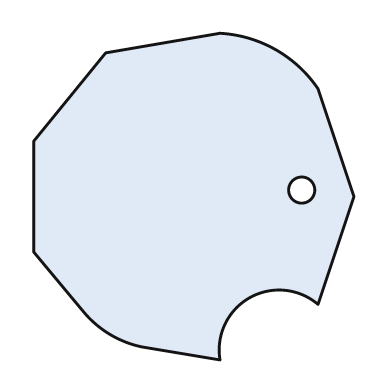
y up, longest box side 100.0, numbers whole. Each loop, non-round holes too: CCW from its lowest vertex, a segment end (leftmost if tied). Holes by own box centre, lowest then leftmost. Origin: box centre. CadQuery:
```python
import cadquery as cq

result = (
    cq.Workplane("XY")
    .moveTo(8.0, -50.0)
    .threePointArc((17.0, -31.0), (38.0, -33.0))
    .lineTo(49.0, 0.0)
    .lineTo(38.0, 33.0)
    .threePointArc((25.0, 45.0), (8.0, 50.0))
    .lineTo(-27.0, 44.0)
    .lineTo(-49.0, 17.0)
    .lineTo(-49.0, -17.0)
    .lineTo(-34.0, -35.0)
    .threePointArc((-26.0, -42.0), (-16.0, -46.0))
    .close()
    .moveTo(33.0, 2.0)
    .circle(4.0)
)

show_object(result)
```